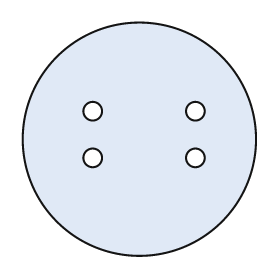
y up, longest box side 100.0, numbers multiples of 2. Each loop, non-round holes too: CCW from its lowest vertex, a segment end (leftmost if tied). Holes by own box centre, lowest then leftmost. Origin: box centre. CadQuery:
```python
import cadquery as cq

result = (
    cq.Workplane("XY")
    .moveTo(0.0, 0.0)
    .circle(50.0)
    .moveTo(-20.0, -8.0)
    .circle(4.0)
    .moveTo(24.0, -8.0)
    .circle(4.0)
    .moveTo(-20.0, 12.0)
    .circle(4.0)
    .moveTo(24.0, 12.0)
    .circle(4.0)
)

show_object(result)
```